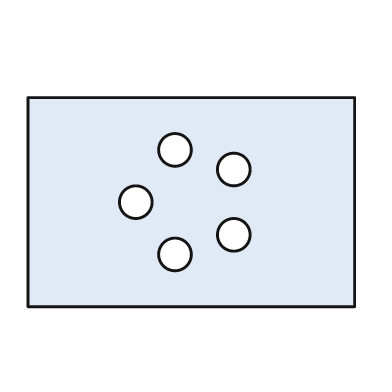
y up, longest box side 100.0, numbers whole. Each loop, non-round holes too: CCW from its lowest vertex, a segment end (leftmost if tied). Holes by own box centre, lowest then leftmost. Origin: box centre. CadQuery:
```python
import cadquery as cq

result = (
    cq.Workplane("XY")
    .moveTo(-50.0, -32.0)
    .lineTo(50.0, -32.0)
    .lineTo(50.0, 32.0)
    .lineTo(-50.0, 32.0)
    .close()
    .moveTo(-5.0, -16.0)
    .circle(5.0)
    .moveTo(13.0, -10.0)
    .circle(5.0)
    .moveTo(-17.0, 0.0)
    .circle(5.0)
    .moveTo(13.0, 10.0)
    .circle(5.0)
    .moveTo(-5.0, 16.0)
    .circle(5.0)
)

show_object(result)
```